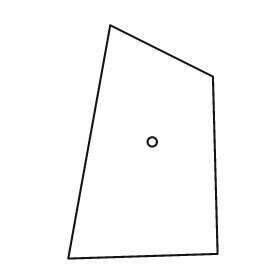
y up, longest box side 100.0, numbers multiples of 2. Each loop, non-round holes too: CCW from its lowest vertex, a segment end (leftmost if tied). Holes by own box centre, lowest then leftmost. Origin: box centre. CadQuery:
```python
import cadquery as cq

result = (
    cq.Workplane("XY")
    .moveTo(-32.0, -50.0)
    .lineTo(32.0, -48.0)
    .lineTo(30.0, 28.0)
    .lineTo(-14.0, 50.0)
    .close()
    .moveTo(4.0, 0.0)
    .circle(2.0)
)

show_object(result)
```